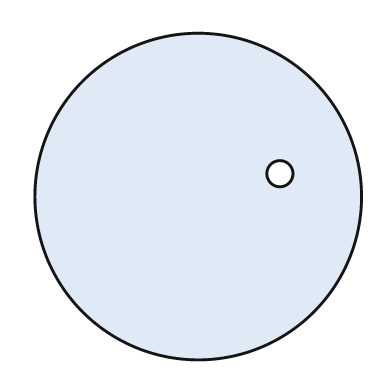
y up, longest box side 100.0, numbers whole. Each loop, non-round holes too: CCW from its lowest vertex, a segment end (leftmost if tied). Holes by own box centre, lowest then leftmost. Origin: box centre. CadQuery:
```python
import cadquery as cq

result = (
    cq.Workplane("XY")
    .moveTo(0.0, 0.0)
    .circle(50.0)
    .moveTo(25.0, 7.0)
    .circle(4.0)
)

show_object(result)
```